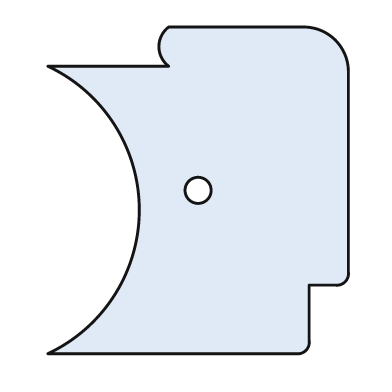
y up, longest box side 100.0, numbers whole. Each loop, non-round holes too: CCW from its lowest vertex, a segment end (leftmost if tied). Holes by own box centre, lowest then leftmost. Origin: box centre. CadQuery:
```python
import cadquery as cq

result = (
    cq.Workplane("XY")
    .moveTo(-46.0, -50.0)
    .lineTo(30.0, -50.0)
    .threePointArc((33.0, -49.0), (34.0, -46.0))
    .lineTo(34.0, -29.0)
    .lineTo(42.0, -29.0)
    .threePointArc((45.0, -28.0), (46.0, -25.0))
    .lineTo(46.0, 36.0)
    .threePointArc((42.0, 46.0), (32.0, 50.0))
    .lineTo(-9.0, 50.0)
    .threePointArc((-12.0, 44.0), (-9.0, 38.0))
    .lineTo(-46.0, 38.0)
    .threePointArc((-18.0, -6.0), (-46.0, -50.0))
    .close()
    .moveTo(0.0, 0.0)
    .circle(4.0)
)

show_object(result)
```